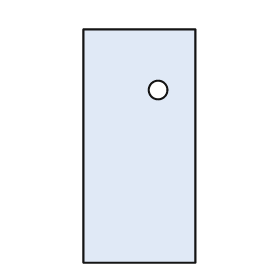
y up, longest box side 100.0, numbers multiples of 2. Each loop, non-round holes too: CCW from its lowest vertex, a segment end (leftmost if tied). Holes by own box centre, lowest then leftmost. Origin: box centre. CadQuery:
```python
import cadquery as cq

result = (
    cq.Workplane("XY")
    .moveTo(-24.0, -50.0)
    .lineTo(24.0, -50.0)
    .lineTo(24.0, 50.0)
    .lineTo(-24.0, 50.0)
    .close()
    .moveTo(8.0, 24.0)
    .circle(4.0)
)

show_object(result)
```